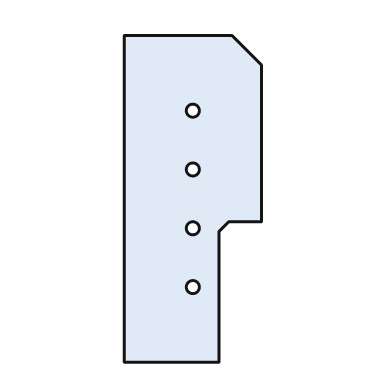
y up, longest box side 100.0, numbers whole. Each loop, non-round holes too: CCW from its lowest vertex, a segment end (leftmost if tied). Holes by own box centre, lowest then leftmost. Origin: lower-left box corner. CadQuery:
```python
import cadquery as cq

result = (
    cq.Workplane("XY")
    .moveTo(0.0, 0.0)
    .lineTo(29.0, 0.0)
    .lineTo(29.0, 40.0)
    .lineTo(32.0, 43.0)
    .lineTo(42.0, 43.0)
    .lineTo(42.0, 91.0)
    .lineTo(33.0, 100.0)
    .lineTo(0.0, 100.0)
    .close()
    .moveTo(21.0, 23.0)
    .circle(2.0)
    .moveTo(21.0, 41.0)
    .circle(2.0)
    .moveTo(21.0, 59.0)
    .circle(2.0)
    .moveTo(21.0, 77.0)
    .circle(2.0)
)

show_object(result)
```